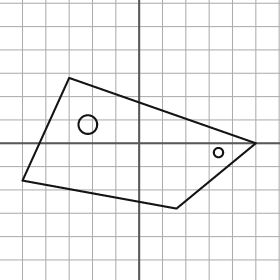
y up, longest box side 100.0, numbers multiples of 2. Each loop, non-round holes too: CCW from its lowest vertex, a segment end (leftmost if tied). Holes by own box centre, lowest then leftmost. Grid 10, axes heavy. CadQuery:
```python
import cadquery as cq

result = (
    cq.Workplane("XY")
    .moveTo(16.0, -28.0)
    .lineTo(50.0, 0.0)
    .lineTo(-30.0, 28.0)
    .lineTo(-50.0, -16.0)
    .close()
    .moveTo(34.0, -4.0)
    .circle(2.0)
    .moveTo(-22.0, 8.0)
    .circle(4.0)
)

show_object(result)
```